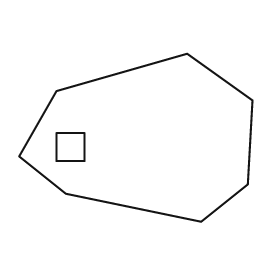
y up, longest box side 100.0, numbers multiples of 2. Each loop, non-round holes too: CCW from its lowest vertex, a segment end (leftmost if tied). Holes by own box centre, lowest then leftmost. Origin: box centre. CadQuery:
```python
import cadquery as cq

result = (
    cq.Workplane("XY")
    .moveTo(28.0, -36.0)
    .lineTo(48.0, -20.0)
    .lineTo(50.0, 16.0)
    .lineTo(22.0, 36.0)
    .lineTo(-34.0, 20.0)
    .lineTo(-50.0, -8.0)
    .lineTo(-30.0, -24.0)
    .close()
    .moveTo(-34.0, -10.0)
    .lineTo(-22.0, -10.0)
    .lineTo(-22.0, 2.0)
    .lineTo(-34.0, 2.0)
    .close()
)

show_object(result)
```